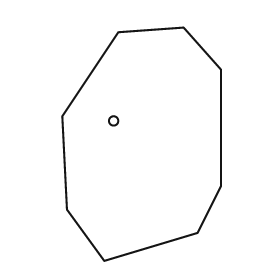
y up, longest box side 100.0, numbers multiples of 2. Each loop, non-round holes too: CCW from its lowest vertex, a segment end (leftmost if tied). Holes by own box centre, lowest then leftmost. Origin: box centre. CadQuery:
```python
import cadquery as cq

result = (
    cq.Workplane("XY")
    .moveTo(-16.0, -50.0)
    .lineTo(24.0, -38.0)
    .lineTo(34.0, -18.0)
    .lineTo(34.0, 32.0)
    .lineTo(18.0, 50.0)
    .lineTo(-10.0, 48.0)
    .lineTo(-34.0, 12.0)
    .lineTo(-32.0, -28.0)
    .close()
    .moveTo(-12.0, 10.0)
    .circle(2.0)
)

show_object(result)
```